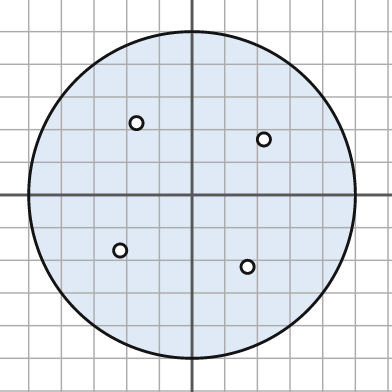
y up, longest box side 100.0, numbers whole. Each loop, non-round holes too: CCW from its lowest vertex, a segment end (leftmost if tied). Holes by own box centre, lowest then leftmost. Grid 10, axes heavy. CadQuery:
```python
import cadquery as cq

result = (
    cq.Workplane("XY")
    .moveTo(0.0, 0.0)
    .circle(50.0)
    .moveTo(17.0, -22.0)
    .circle(2.0)
    .moveTo(-22.0, -17.0)
    .circle(2.0)
    .moveTo(22.0, 17.0)
    .circle(2.0)
    .moveTo(-17.0, 22.0)
    .circle(2.0)
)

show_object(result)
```